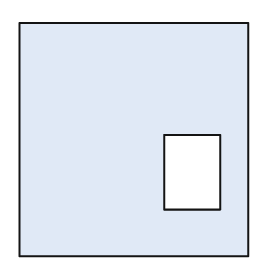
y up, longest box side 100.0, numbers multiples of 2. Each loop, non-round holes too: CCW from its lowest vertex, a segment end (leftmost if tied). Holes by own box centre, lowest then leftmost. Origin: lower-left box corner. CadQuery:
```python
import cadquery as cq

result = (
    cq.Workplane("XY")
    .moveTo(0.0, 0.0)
    .lineTo(98.0, 0.0)
    .lineTo(98.0, 100.0)
    .lineTo(0.0, 100.0)
    .close()
    .moveTo(62.0, 20.0)
    .lineTo(86.0, 20.0)
    .lineTo(86.0, 52.0)
    .lineTo(62.0, 52.0)
    .close()
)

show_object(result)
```